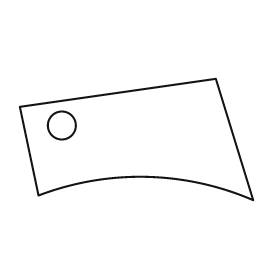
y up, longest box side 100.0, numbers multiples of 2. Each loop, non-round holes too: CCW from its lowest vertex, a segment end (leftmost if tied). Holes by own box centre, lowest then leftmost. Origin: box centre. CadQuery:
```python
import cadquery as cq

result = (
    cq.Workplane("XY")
    .moveTo(50.0, -26.0)
    .lineTo(34.0, 26.0)
    .lineTo(-50.0, 14.0)
    .lineTo(-42.0, -24.0)
    .threePointArc((4.0, -16.0), (50.0, -26.0))
    .close()
    .moveTo(-32.0, 6.0)
    .circle(6.0)
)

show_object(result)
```